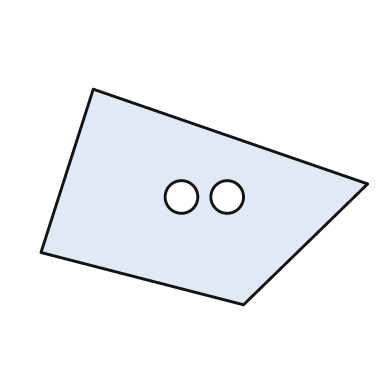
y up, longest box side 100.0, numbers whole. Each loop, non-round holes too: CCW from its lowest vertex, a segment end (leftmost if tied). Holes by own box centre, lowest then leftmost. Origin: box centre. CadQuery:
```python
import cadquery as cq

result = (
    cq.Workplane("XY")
    .moveTo(12.0, -33.0)
    .lineTo(50.0, 4.0)
    .lineTo(-34.0, 33.0)
    .lineTo(-50.0, -17.0)
    .close()
    .moveTo(-7.0, 0.0)
    .circle(5.0)
    .moveTo(7.0, 0.0)
    .circle(5.0)
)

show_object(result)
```